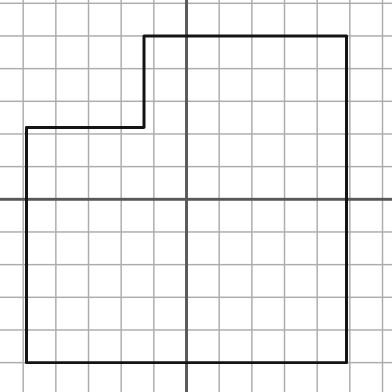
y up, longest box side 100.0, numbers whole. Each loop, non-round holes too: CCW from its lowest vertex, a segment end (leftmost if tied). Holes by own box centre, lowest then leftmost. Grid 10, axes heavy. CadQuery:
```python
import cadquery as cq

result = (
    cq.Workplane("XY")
    .moveTo(-49.0, -50.0)
    .lineTo(49.0, -50.0)
    .lineTo(49.0, 50.0)
    .lineTo(-13.0, 50.0)
    .lineTo(-13.0, 22.0)
    .lineTo(-49.0, 22.0)
    .close()
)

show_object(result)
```